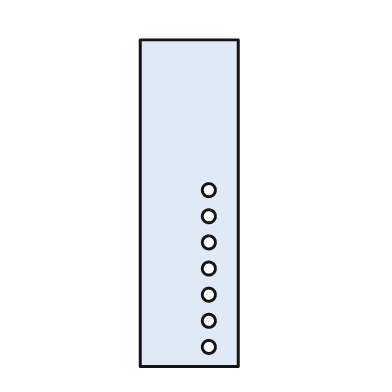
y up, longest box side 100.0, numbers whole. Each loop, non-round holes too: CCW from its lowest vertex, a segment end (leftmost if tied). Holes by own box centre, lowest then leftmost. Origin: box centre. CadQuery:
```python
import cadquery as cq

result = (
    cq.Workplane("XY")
    .moveTo(-15.0, -50.0)
    .lineTo(15.0, -50.0)
    .lineTo(15.0, 50.0)
    .lineTo(-15.0, 50.0)
    .close()
    .moveTo(6.0, -44.0)
    .circle(2.0)
    .moveTo(6.0, -36.0)
    .circle(2.0)
    .moveTo(6.0, -28.0)
    .circle(2.0)
    .moveTo(6.0, -20.0)
    .circle(2.0)
    .moveTo(6.0, -12.0)
    .circle(2.0)
    .moveTo(6.0, -4.0)
    .circle(2.0)
    .moveTo(6.0, 4.0)
    .circle(2.0)
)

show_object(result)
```